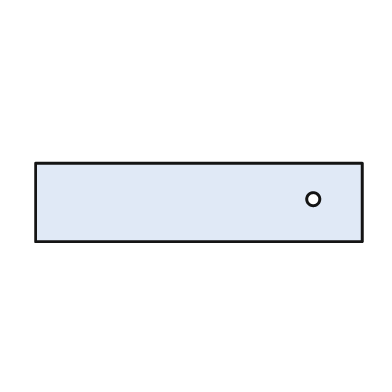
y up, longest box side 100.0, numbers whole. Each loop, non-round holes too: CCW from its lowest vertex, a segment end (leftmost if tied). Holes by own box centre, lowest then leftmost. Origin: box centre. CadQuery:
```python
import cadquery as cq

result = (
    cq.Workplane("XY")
    .moveTo(-50.0, -12.0)
    .lineTo(50.0, -12.0)
    .lineTo(50.0, 12.0)
    .lineTo(-50.0, 12.0)
    .close()
    .moveTo(35.0, 1.0)
    .circle(2.0)
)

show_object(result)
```